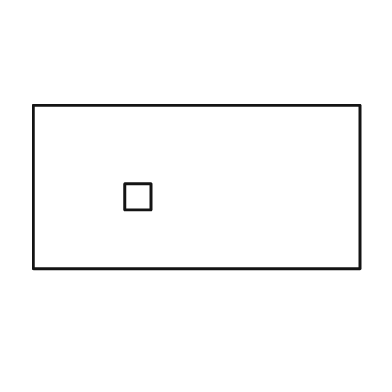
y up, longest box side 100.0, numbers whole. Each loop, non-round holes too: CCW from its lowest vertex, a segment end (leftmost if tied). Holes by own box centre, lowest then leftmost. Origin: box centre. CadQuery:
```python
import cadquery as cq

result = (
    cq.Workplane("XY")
    .moveTo(-50.0, -25.0)
    .lineTo(50.0, -25.0)
    .lineTo(50.0, 25.0)
    .lineTo(-50.0, 25.0)
    .close()
    .moveTo(-22.0, -7.0)
    .lineTo(-14.0, -7.0)
    .lineTo(-14.0, 1.0)
    .lineTo(-22.0, 1.0)
    .close()
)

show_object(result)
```